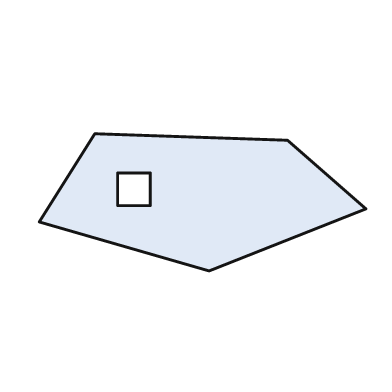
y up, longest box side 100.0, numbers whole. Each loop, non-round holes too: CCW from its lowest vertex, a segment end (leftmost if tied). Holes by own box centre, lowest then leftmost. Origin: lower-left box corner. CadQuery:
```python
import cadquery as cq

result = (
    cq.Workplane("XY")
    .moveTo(52.0, 0.0)
    .lineTo(100.0, 19.0)
    .lineTo(76.0, 40.0)
    .lineTo(17.0, 42.0)
    .lineTo(0.0, 15.0)
    .close()
    .moveTo(24.0, 20.0)
    .lineTo(34.0, 20.0)
    .lineTo(34.0, 30.0)
    .lineTo(24.0, 30.0)
    .close()
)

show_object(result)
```